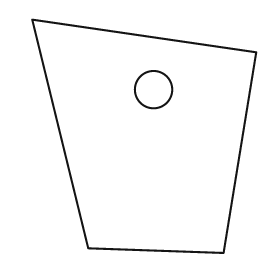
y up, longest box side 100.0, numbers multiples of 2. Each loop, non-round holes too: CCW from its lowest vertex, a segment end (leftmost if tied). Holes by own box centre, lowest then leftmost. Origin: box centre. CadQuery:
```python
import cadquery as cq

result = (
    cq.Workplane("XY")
    .moveTo(34.0, -50.0)
    .lineTo(48.0, 36.0)
    .lineTo(-48.0, 50.0)
    .lineTo(-24.0, -48.0)
    .close()
    .moveTo(4.0, 20.0)
    .circle(8.0)
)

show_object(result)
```